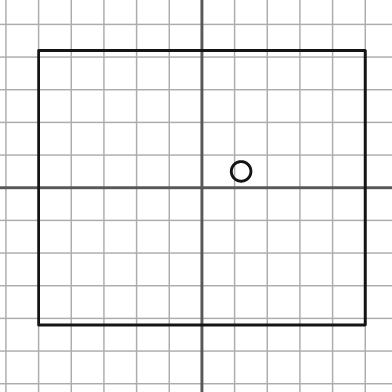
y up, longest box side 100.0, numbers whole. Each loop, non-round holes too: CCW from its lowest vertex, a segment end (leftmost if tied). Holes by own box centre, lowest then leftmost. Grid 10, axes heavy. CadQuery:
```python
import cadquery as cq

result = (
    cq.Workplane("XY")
    .moveTo(-50.0, -42.0)
    .lineTo(50.0, -42.0)
    .lineTo(50.0, 42.0)
    .lineTo(-50.0, 42.0)
    .close()
    .moveTo(12.0, 5.0)
    .circle(3.0)
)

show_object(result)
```